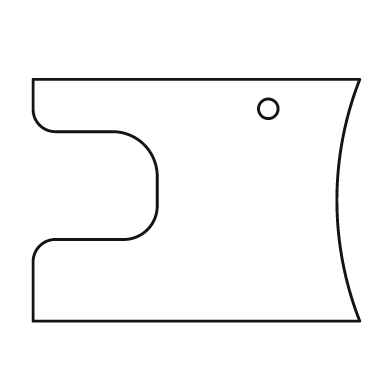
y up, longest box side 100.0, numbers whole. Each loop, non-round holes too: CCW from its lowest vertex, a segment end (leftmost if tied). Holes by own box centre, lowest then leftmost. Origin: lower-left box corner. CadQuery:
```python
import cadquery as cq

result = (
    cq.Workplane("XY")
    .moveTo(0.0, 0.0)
    .lineTo(100.0, 0.0)
    .threePointArc((93.0, 37.0), (100.0, 74.0))
    .lineTo(0.0, 74.0)
    .lineTo(0.0, 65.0)
    .threePointArc((2.0, 60.0), (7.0, 58.0))
    .lineTo(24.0, 58.0)
    .threePointArc((34.0, 54.0), (38.0, 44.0))
    .lineTo(38.0, 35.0)
    .threePointArc((35.0, 28.0), (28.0, 25.0))
    .lineTo(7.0, 25.0)
    .threePointArc((2.0, 23.0), (0.0, 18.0))
    .close()
    .moveTo(72.0, 65.0)
    .circle(3.0)
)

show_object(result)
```